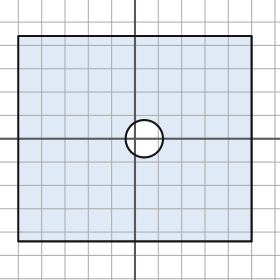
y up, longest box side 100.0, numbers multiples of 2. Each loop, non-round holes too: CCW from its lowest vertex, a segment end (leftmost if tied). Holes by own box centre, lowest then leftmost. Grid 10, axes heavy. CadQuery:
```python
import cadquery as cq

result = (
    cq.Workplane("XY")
    .moveTo(-50.0, -44.0)
    .lineTo(50.0, -44.0)
    .lineTo(50.0, 44.0)
    .lineTo(-50.0, 44.0)
    .close()
    .moveTo(4.0, 0.0)
    .circle(8.0)
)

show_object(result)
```